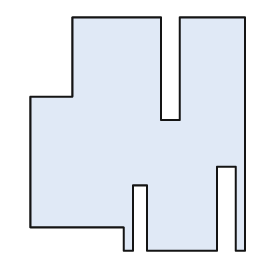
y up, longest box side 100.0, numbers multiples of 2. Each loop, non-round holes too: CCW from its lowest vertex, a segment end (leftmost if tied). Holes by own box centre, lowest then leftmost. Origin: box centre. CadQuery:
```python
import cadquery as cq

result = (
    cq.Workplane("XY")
    .moveTo(-6.0, -50.0)
    .lineTo(-2.0, -50.0)
    .lineTo(-2.0, -22.0)
    .lineTo(4.0, -22.0)
    .lineTo(4.0, -50.0)
    .lineTo(34.0, -50.0)
    .lineTo(34.0, -14.0)
    .lineTo(42.0, -14.0)
    .lineTo(42.0, -50.0)
    .lineTo(46.0, -50.0)
    .lineTo(46.0, 50.0)
    .lineTo(18.0, 50.0)
    .lineTo(18.0, 6.0)
    .lineTo(10.0, 6.0)
    .lineTo(10.0, 50.0)
    .lineTo(-28.0, 50.0)
    .lineTo(-28.0, 16.0)
    .lineTo(-46.0, 16.0)
    .lineTo(-46.0, -40.0)
    .lineTo(-6.0, -40.0)
    .close()
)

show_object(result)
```